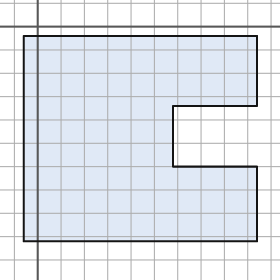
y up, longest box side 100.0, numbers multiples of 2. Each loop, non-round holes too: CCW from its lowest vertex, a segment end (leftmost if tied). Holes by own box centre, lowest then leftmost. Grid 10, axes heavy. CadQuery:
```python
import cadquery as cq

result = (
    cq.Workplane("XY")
    .moveTo(-6.0, -92.0)
    .lineTo(94.0, -92.0)
    .lineTo(94.0, -60.0)
    .lineTo(58.0, -60.0)
    .lineTo(58.0, -34.0)
    .lineTo(94.0, -34.0)
    .lineTo(94.0, -4.0)
    .lineTo(-6.0, -4.0)
    .close()
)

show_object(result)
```